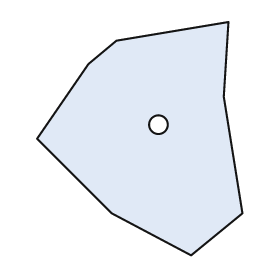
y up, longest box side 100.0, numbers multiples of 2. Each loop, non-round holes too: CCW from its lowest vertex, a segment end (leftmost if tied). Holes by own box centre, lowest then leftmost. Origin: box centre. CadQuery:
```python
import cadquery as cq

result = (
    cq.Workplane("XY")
    .moveTo(22.0, -50.0)
    .lineTo(44.0, -32.0)
    .lineTo(36.0, 18.0)
    .lineTo(38.0, 50.0)
    .lineTo(-10.0, 42.0)
    .lineTo(-22.0, 32.0)
    .lineTo(-44.0, 0.0)
    .lineTo(-12.0, -32.0)
    .close()
    .moveTo(8.0, 6.0)
    .circle(4.0)
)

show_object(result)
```